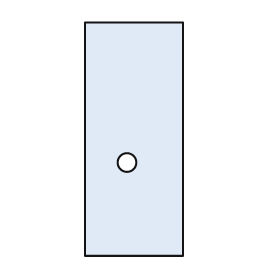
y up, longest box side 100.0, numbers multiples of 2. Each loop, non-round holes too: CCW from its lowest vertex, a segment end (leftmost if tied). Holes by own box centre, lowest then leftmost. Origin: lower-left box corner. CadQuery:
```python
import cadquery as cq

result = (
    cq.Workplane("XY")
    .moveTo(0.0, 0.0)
    .lineTo(42.0, 0.0)
    .lineTo(42.0, 100.0)
    .lineTo(0.0, 100.0)
    .close()
    .moveTo(18.0, 40.0)
    .circle(4.0)
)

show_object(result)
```